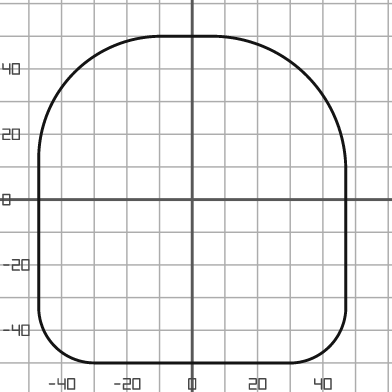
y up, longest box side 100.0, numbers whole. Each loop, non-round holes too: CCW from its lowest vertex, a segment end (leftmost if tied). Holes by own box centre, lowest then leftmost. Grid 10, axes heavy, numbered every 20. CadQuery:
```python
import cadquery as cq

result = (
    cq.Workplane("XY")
    .moveTo(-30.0, -50.0)
    .lineTo(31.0, -50.0)
    .threePointArc((42.0, -45.0), (47.0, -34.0))
    .lineTo(47.0, 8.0)
    .threePointArc((35.0, 38.0), (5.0, 50.0))
    .lineTo(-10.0, 50.0)
    .threePointArc((-36.0, 39.0), (-47.0, 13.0))
    .lineTo(-47.0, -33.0)
    .threePointArc((-42.0, -45.0), (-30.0, -50.0))
    .close()
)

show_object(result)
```